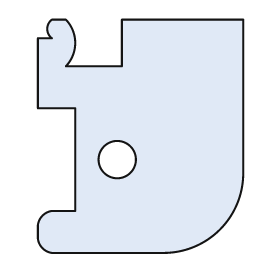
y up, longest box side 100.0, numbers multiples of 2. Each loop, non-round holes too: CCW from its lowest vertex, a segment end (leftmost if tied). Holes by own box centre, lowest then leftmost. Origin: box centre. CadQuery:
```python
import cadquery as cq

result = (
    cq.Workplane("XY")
    .moveTo(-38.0, -50.0)
    .lineTo(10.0, -50.0)
    .threePointArc((34.0, -40.0), (44.0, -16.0))
    .lineTo(44.0, 50.0)
    .lineTo(-8.0, 50.0)
    .lineTo(-8.0, 30.0)
    .lineTo(-32.0, 30.0)
    .threePointArc((-28.0, 40.0), (-32.0, 50.0))
    .lineTo(-38.0, 50.0)
    .threePointArc((-40.0, 46.0), (-38.0, 42.0))
    .lineTo(-44.0, 42.0)
    .lineTo(-44.0, 12.0)
    .lineTo(-28.0, 12.0)
    .lineTo(-28.0, -32.0)
    .lineTo(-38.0, -32.0)
    .threePointArc((-42.0, -34.0), (-44.0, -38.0))
    .lineTo(-44.0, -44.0)
    .threePointArc((-42.0, -48.0), (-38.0, -50.0))
    .close()
    .moveTo(-10.0, -10.0)
    .circle(8.0)
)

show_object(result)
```